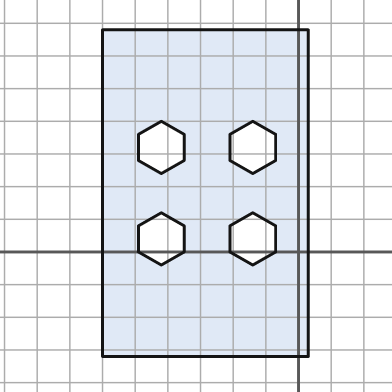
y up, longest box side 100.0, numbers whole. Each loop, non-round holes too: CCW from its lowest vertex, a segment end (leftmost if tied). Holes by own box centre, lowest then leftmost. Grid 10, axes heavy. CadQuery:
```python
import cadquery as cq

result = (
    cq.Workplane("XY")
    .moveTo(-60.0, -32.0)
    .lineTo(3.0, -32.0)
    .lineTo(3.0, 68.0)
    .lineTo(-60.0, 68.0)
    .close()
    .moveTo(-42.0, -4.0)
    .lineTo(-35.0, 0.0)
    .lineTo(-35.0, 8.0)
    .lineTo(-42.0, 12.0)
    .lineTo(-49.0, 8.0)
    .lineTo(-49.0, 0.0)
    .close()
    .moveTo(-14.0, -4.0)
    .lineTo(-7.0, 0.0)
    .lineTo(-7.0, 8.0)
    .lineTo(-14.0, 12.0)
    .lineTo(-21.0, 8.0)
    .lineTo(-21.0, 0.0)
    .close()
    .moveTo(-42.0, 24.0)
    .lineTo(-35.0, 28.0)
    .lineTo(-35.0, 36.0)
    .lineTo(-42.0, 40.0)
    .lineTo(-49.0, 36.0)
    .lineTo(-49.0, 28.0)
    .close()
    .moveTo(-14.0, 24.0)
    .lineTo(-7.0, 28.0)
    .lineTo(-7.0, 36.0)
    .lineTo(-14.0, 40.0)
    .lineTo(-21.0, 36.0)
    .lineTo(-21.0, 28.0)
    .close()
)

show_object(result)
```